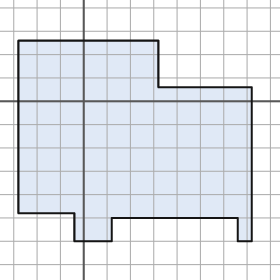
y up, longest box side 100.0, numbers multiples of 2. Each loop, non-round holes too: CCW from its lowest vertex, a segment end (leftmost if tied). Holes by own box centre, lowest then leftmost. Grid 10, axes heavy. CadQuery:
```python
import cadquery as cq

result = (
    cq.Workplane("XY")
    .moveTo(-4.0, -60.0)
    .lineTo(12.0, -60.0)
    .lineTo(12.0, -50.0)
    .lineTo(66.0, -50.0)
    .lineTo(66.0, -60.0)
    .lineTo(72.0, -60.0)
    .lineTo(72.0, 6.0)
    .lineTo(32.0, 6.0)
    .lineTo(32.0, 26.0)
    .lineTo(-28.0, 26.0)
    .lineTo(-28.0, -48.0)
    .lineTo(-4.0, -48.0)
    .close()
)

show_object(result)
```